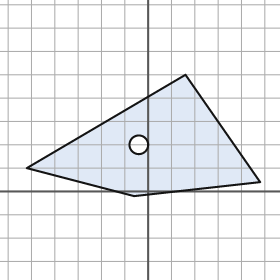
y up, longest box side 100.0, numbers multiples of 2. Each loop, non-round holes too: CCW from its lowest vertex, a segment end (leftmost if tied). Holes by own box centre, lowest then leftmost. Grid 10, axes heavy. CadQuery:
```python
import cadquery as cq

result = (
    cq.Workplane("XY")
    .moveTo(-6.0, -2.0)
    .lineTo(48.0, 4.0)
    .lineTo(16.0, 50.0)
    .lineTo(-52.0, 10.0)
    .close()
    .moveTo(-4.0, 20.0)
    .circle(4.0)
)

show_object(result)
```